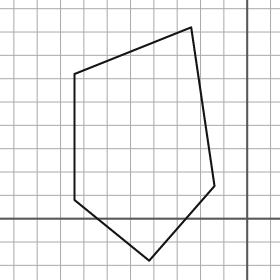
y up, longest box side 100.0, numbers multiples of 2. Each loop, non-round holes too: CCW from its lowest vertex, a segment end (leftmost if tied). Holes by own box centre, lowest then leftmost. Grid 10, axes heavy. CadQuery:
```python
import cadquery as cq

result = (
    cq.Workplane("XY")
    .moveTo(-42.0, -18.0)
    .lineTo(-14.0, 14.0)
    .lineTo(-24.0, 82.0)
    .lineTo(-74.0, 62.0)
    .lineTo(-74.0, 8.0)
    .close()
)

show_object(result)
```